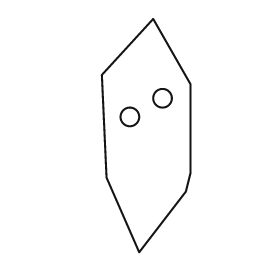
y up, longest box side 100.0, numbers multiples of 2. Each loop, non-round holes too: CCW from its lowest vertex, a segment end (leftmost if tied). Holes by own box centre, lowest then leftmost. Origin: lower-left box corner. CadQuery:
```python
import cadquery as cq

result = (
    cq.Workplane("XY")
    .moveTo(16.0, 0.0)
    .lineTo(36.0, 26.0)
    .lineTo(38.0, 34.0)
    .lineTo(38.0, 72.0)
    .lineTo(22.0, 100.0)
    .lineTo(0.0, 76.0)
    .lineTo(2.0, 32.0)
    .close()
    .moveTo(12.0, 58.0)
    .circle(4.0)
    .moveTo(26.0, 66.0)
    .circle(4.0)
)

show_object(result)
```